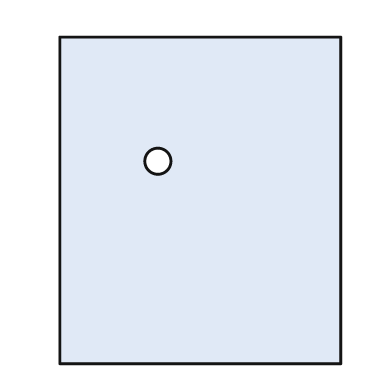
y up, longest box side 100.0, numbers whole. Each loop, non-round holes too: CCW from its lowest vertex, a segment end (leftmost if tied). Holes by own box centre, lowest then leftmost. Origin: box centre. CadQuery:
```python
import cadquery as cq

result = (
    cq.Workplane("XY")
    .moveTo(-43.0, -50.0)
    .lineTo(43.0, -50.0)
    .lineTo(43.0, 50.0)
    .lineTo(-43.0, 50.0)
    .close()
    .moveTo(-13.0, 12.0)
    .circle(4.0)
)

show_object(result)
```